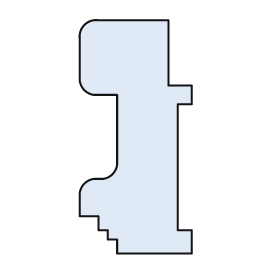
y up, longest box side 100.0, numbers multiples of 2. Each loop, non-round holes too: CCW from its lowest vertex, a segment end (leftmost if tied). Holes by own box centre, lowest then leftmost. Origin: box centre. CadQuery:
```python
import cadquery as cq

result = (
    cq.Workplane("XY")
    .moveTo(-8.0, -50.0)
    .lineTo(24.0, -50.0)
    .lineTo(24.0, -40.0)
    .lineTo(18.0, -40.0)
    .lineTo(18.0, 14.0)
    .lineTo(24.0, 14.0)
    .lineTo(24.0, 22.0)
    .lineTo(14.0, 22.0)
    .lineTo(14.0, 50.0)
    .lineTo(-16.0, 50.0)
    .threePointArc((-22.0, 48.0), (-24.0, 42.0))
    .lineTo(-24.0, 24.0)
    .threePointArc((-22.0, 20.0), (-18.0, 18.0))
    .lineTo(-8.0, 18.0)
    .lineTo(-8.0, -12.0)
    .threePointArc((-10.0, -16.0), (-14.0, -18.0))
    .lineTo(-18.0, -18.0)
    .threePointArc((-22.0, -20.0), (-24.0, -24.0))
    .lineTo(-24.0, -34.0)
    .lineTo(-16.0, -34.0)
    .lineTo(-16.0, -40.0)
    .lineTo(-12.0, -40.0)
    .lineTo(-12.0, -44.0)
    .lineTo(-8.0, -44.0)
    .close()
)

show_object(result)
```